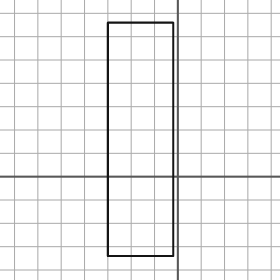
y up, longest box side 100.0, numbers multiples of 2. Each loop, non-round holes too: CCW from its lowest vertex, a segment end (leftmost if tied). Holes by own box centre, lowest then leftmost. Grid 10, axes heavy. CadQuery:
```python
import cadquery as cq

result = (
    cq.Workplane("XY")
    .moveTo(-30.0, -34.0)
    .lineTo(-2.0, -34.0)
    .lineTo(-2.0, 66.0)
    .lineTo(-30.0, 66.0)
    .close()
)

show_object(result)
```